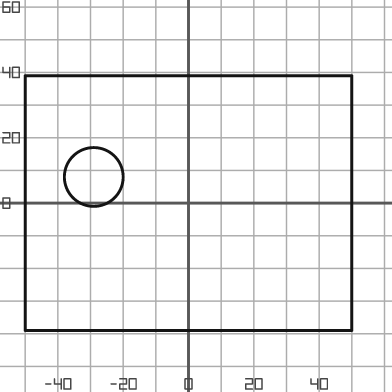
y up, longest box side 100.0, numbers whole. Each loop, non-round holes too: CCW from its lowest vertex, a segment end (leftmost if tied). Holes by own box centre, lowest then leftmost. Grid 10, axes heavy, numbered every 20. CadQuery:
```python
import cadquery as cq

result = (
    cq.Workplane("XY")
    .moveTo(-50.0, -39.0)
    .lineTo(50.0, -39.0)
    .lineTo(50.0, 39.0)
    .lineTo(-50.0, 39.0)
    .close()
    .moveTo(-29.0, 8.0)
    .circle(9.0)
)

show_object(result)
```